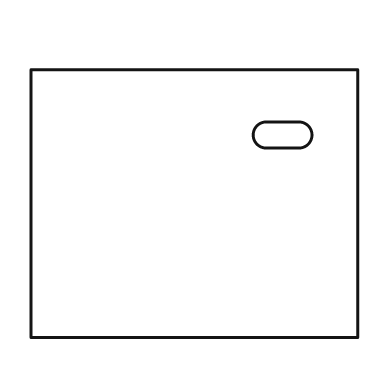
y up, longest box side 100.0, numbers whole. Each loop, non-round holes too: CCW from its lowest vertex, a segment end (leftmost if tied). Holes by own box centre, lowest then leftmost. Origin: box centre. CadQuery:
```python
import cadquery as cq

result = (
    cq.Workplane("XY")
    .moveTo(-50.0, -41.0)
    .lineTo(50.0, -41.0)
    .lineTo(50.0, 41.0)
    .lineTo(-50.0, 41.0)
    .close()
    .moveTo(22.0, 17.0)
    .lineTo(32.0, 17.0)
    .threePointArc((36.0, 21.0), (32.0, 25.0))
    .lineTo(22.0, 25.0)
    .threePointArc((18.0, 21.0), (22.0, 17.0))
    .close()
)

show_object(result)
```